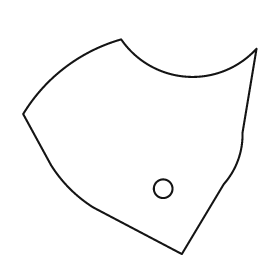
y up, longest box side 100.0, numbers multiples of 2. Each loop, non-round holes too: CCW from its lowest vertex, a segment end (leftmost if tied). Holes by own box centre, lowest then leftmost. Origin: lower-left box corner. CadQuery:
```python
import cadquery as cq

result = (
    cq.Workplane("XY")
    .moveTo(68.0, 0.0)
    .lineTo(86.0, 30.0)
    .threePointArc((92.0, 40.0), (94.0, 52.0))
    .lineTo(100.0, 88.0)
    .threePointArc((70.0, 76.0), (42.0, 92.0))
    .threePointArc((18.0, 80.0), (0.0, 60.0))
    .lineTo(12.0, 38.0)
    .threePointArc((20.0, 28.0), (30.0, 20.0))
    .close()
    .moveTo(60.0, 28.0)
    .circle(4.0)
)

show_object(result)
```